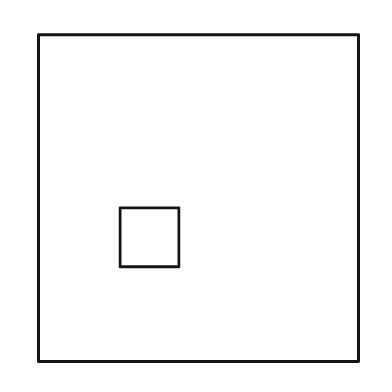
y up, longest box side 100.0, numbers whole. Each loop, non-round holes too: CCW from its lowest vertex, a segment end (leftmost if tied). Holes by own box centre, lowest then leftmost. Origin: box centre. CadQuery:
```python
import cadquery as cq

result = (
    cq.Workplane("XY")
    .moveTo(-49.0, -50.0)
    .lineTo(49.0, -50.0)
    .lineTo(49.0, 50.0)
    .lineTo(-49.0, 50.0)
    .close()
    .moveTo(-24.0, -21.0)
    .lineTo(-6.0, -21.0)
    .lineTo(-6.0, -3.0)
    .lineTo(-24.0, -3.0)
    .close()
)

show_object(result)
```